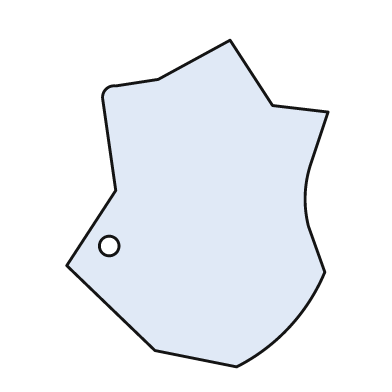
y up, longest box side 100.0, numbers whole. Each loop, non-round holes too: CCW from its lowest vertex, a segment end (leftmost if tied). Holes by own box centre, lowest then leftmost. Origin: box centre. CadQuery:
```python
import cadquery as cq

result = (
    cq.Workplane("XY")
    .moveTo(12.0, -50.0)
    .threePointArc((28.0, -38.0), (39.0, -21.0))
    .lineTo(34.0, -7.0)
    .threePointArc((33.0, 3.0), (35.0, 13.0))
    .lineTo(40.0, 28.0)
    .lineTo(23.0, 30.0)
    .lineTo(10.0, 50.0)
    .lineTo(-12.0, 38.0)
    .lineTo(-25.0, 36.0)
    .threePointArc((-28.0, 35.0), (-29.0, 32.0))
    .lineTo(-25.0, 4.0)
    .lineTo(-40.0, -19.0)
    .lineTo(-13.0, -45.0)
    .close()
    .moveTo(-27.0, -13.0)
    .circle(3.0)
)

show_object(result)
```